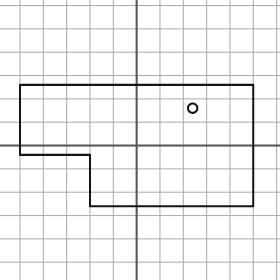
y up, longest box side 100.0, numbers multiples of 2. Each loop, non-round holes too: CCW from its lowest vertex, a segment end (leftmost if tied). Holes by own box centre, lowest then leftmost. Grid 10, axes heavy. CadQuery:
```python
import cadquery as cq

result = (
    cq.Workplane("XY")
    .moveTo(-20.0, -26.0)
    .lineTo(50.0, -26.0)
    .lineTo(50.0, 26.0)
    .lineTo(-50.0, 26.0)
    .lineTo(-50.0, -4.0)
    .lineTo(-20.0, -4.0)
    .close()
    .moveTo(24.0, 16.0)
    .circle(2.0)
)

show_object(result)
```